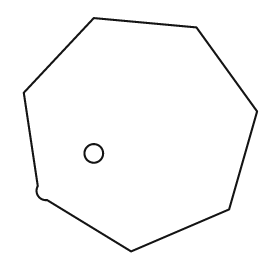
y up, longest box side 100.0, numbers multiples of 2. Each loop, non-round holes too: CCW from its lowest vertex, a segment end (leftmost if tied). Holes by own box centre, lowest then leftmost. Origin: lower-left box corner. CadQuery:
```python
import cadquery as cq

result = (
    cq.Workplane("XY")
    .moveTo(46.0, 0.0)
    .lineTo(88.0, 18.0)
    .lineTo(100.0, 60.0)
    .lineTo(74.0, 96.0)
    .lineTo(30.0, 100.0)
    .lineTo(0.0, 68.0)
    .lineTo(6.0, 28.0)
    .threePointArc((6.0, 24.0), (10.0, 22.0))
    .close()
    .moveTo(30.0, 42.0)
    .circle(4.0)
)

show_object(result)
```